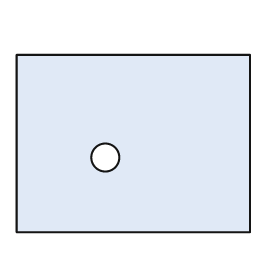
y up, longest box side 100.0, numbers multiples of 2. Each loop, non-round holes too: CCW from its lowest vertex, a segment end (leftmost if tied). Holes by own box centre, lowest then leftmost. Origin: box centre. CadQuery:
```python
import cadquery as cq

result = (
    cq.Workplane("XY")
    .moveTo(-50.0, -38.0)
    .lineTo(50.0, -38.0)
    .lineTo(50.0, 38.0)
    .lineTo(-50.0, 38.0)
    .close()
    .moveTo(-12.0, -6.0)
    .circle(6.0)
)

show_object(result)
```